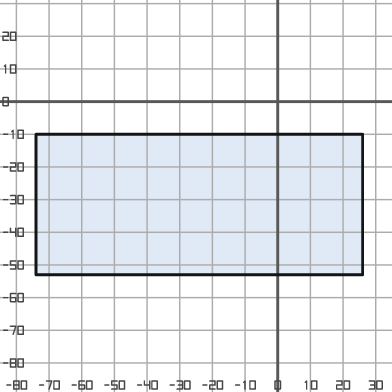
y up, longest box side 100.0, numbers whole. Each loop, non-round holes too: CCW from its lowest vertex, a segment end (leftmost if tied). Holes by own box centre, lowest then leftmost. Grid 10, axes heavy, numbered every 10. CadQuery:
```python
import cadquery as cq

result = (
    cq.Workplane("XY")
    .moveTo(-74.0, -53.0)
    .lineTo(26.0, -53.0)
    .lineTo(26.0, -10.0)
    .lineTo(-74.0, -10.0)
    .close()
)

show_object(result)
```